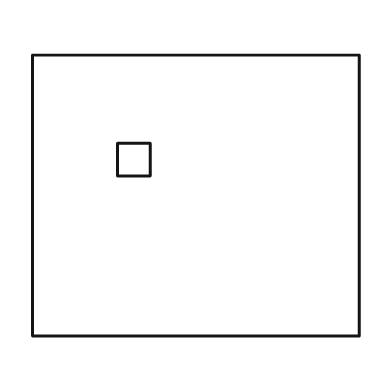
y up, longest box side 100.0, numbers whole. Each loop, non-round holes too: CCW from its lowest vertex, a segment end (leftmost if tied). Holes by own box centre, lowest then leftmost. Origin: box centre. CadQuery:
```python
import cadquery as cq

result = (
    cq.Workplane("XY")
    .moveTo(-50.0, -43.0)
    .lineTo(50.0, -43.0)
    .lineTo(50.0, 43.0)
    .lineTo(-50.0, 43.0)
    .close()
    .moveTo(-24.0, 6.0)
    .lineTo(-14.0, 6.0)
    .lineTo(-14.0, 16.0)
    .lineTo(-24.0, 16.0)
    .close()
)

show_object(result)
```